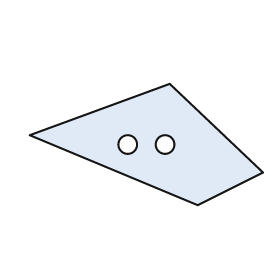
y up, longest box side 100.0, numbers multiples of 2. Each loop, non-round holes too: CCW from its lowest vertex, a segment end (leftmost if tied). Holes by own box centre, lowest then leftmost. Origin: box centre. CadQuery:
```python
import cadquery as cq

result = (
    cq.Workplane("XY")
    .moveTo(22.0, -26.0)
    .lineTo(50.0, -12.0)
    .lineTo(10.0, 26.0)
    .lineTo(-50.0, 4.0)
    .close()
    .moveTo(-8.0, 0.0)
    .circle(4.0)
    .moveTo(8.0, 0.0)
    .circle(4.0)
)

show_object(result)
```